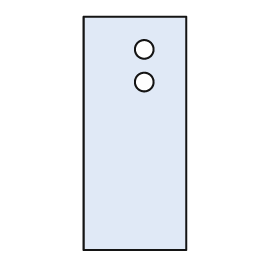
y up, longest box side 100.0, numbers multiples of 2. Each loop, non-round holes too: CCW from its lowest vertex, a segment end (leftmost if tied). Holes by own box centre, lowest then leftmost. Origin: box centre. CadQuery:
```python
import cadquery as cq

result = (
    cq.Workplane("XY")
    .moveTo(-22.0, -50.0)
    .lineTo(22.0, -50.0)
    .lineTo(22.0, 50.0)
    .lineTo(-22.0, 50.0)
    .close()
    .moveTo(4.0, 22.0)
    .circle(4.0)
    .moveTo(4.0, 36.0)
    .circle(4.0)
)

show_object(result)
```